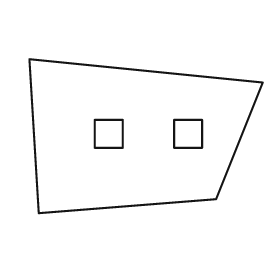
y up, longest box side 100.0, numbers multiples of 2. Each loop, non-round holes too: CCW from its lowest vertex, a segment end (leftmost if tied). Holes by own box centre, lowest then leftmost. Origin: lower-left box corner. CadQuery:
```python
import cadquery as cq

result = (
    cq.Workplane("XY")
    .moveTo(4.0, 0.0)
    .lineTo(80.0, 6.0)
    .lineTo(100.0, 56.0)
    .lineTo(0.0, 66.0)
    .close()
    .moveTo(28.0, 28.0)
    .lineTo(40.0, 28.0)
    .lineTo(40.0, 40.0)
    .lineTo(28.0, 40.0)
    .close()
    .moveTo(62.0, 28.0)
    .lineTo(74.0, 28.0)
    .lineTo(74.0, 40.0)
    .lineTo(62.0, 40.0)
    .close()
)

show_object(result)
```